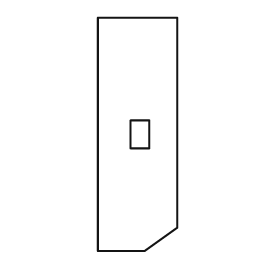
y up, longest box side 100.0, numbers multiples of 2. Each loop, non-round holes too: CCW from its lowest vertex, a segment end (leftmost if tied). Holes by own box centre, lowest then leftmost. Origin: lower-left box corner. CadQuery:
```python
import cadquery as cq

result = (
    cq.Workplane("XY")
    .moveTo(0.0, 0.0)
    .lineTo(20.0, 0.0)
    .lineTo(34.0, 10.0)
    .lineTo(34.0, 100.0)
    .lineTo(0.0, 100.0)
    .close()
    .moveTo(14.0, 44.0)
    .lineTo(22.0, 44.0)
    .lineTo(22.0, 56.0)
    .lineTo(14.0, 56.0)
    .close()
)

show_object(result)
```